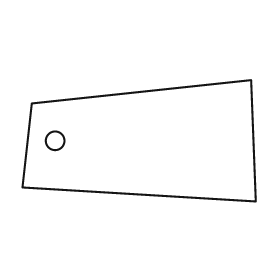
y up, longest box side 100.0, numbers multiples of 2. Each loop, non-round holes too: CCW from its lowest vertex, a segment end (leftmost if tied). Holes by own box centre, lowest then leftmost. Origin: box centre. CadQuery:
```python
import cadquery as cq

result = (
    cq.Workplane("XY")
    .moveTo(50.0, -26.0)
    .lineTo(48.0, 26.0)
    .lineTo(-46.0, 16.0)
    .lineTo(-50.0, -20.0)
    .close()
    .moveTo(-36.0, 0.0)
    .circle(4.0)
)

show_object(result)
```